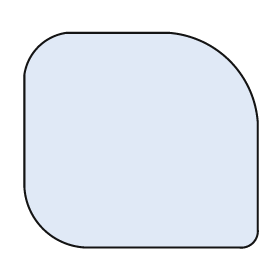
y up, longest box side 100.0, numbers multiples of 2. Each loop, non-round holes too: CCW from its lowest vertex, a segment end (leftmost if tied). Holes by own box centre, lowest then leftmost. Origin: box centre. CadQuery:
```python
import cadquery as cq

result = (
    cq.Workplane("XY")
    .moveTo(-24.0, -46.0)
    .lineTo(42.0, -46.0)
    .threePointArc((48.0, -44.0), (50.0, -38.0))
    .lineTo(50.0, 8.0)
    .threePointArc((38.0, 34.0), (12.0, 46.0))
    .lineTo(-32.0, 46.0)
    .threePointArc((-44.0, 40.0), (-50.0, 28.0))
    .lineTo(-50.0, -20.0)
    .threePointArc((-42.0, -38.0), (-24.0, -46.0))
    .close()
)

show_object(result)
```